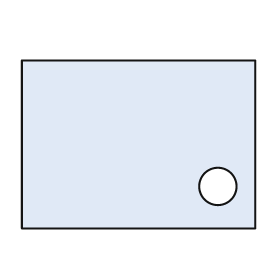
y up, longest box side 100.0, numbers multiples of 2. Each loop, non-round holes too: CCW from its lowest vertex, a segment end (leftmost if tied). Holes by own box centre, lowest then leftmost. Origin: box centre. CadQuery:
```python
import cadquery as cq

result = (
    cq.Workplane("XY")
    .moveTo(-50.0, -36.0)
    .lineTo(50.0, -36.0)
    .lineTo(50.0, 36.0)
    .lineTo(-50.0, 36.0)
    .close()
    .moveTo(34.0, -18.0)
    .circle(8.0)
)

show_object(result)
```